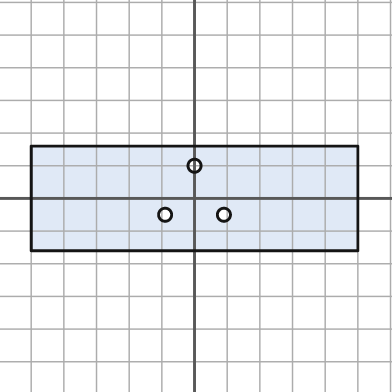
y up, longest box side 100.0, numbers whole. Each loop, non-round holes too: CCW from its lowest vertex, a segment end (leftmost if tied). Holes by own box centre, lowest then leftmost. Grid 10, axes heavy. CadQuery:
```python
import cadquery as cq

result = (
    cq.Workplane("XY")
    .moveTo(-50.0, -16.0)
    .lineTo(50.0, -16.0)
    .lineTo(50.0, 16.0)
    .lineTo(-50.0, 16.0)
    .close()
    .moveTo(-9.0, -5.0)
    .circle(2.0)
    .moveTo(9.0, -5.0)
    .circle(2.0)
    .moveTo(0.0, 10.0)
    .circle(2.0)
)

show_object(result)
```